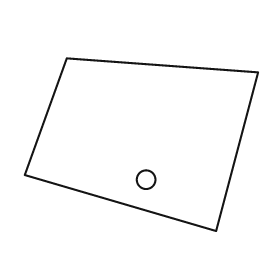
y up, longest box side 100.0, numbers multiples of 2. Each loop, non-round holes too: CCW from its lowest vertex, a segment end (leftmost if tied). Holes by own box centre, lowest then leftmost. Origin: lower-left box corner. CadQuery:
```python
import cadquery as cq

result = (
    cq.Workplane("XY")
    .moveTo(82.0, 0.0)
    .lineTo(100.0, 68.0)
    .lineTo(18.0, 74.0)
    .lineTo(0.0, 24.0)
    .close()
    .moveTo(52.0, 22.0)
    .circle(4.0)
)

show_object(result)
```